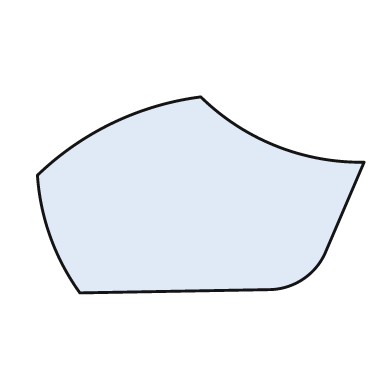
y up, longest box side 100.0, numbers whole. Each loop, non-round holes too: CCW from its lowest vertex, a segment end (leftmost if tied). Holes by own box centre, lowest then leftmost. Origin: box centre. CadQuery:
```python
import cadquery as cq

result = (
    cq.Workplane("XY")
    .moveTo(-37.0, -30.0)
    .lineTo(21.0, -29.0)
    .threePointArc((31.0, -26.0), (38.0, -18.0))
    .lineTo(50.0, 10.0)
    .threePointArc((23.0, 15.0), (0.0, 30.0))
    .threePointArc((-27.0, 22.0), (-50.0, 6.0))
    .threePointArc((-46.0, -13.0), (-37.0, -30.0))
    .close()
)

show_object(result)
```